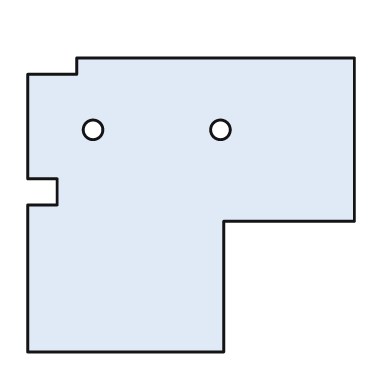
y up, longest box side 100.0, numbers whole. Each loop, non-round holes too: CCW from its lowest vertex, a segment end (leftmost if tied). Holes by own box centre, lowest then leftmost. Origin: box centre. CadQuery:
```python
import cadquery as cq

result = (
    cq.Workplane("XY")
    .moveTo(-50.0, -45.0)
    .lineTo(10.0, -45.0)
    .lineTo(10.0, -5.0)
    .lineTo(50.0, -5.0)
    .lineTo(50.0, 45.0)
    .lineTo(-35.0, 45.0)
    .lineTo(-35.0, 40.0)
    .lineTo(-50.0, 40.0)
    .lineTo(-50.0, 8.0)
    .lineTo(-41.0, 8.0)
    .lineTo(-41.0, 0.0)
    .lineTo(-50.0, 0.0)
    .close()
    .moveTo(-30.0, 23.0)
    .circle(3.0)
    .moveTo(9.0, 23.0)
    .circle(3.0)
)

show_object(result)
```